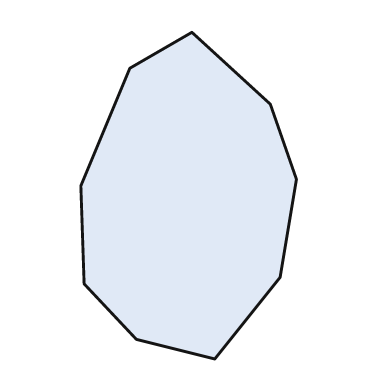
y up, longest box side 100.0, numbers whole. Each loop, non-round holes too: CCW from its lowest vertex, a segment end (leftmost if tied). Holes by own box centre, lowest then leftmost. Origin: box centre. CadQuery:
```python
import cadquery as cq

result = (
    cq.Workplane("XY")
    .moveTo(8.0, -50.0)
    .lineTo(28.0, -25.0)
    .lineTo(33.0, 5.0)
    .lineTo(25.0, 28.0)
    .lineTo(1.0, 50.0)
    .lineTo(-18.0, 39.0)
    .lineTo(-33.0, 3.0)
    .lineTo(-32.0, -27.0)
    .lineTo(-16.0, -44.0)
    .close()
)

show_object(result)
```